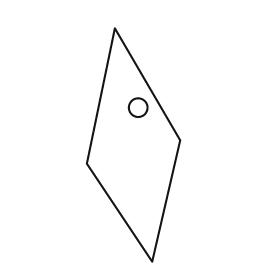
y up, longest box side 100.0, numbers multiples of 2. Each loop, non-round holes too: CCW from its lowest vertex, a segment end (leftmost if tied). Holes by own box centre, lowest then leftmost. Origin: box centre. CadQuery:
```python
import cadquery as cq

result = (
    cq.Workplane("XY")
    .moveTo(8.0, -50.0)
    .lineTo(20.0, 2.0)
    .lineTo(-8.0, 50.0)
    .lineTo(-20.0, -8.0)
    .close()
    .moveTo(2.0, 16.0)
    .circle(4.0)
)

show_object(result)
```